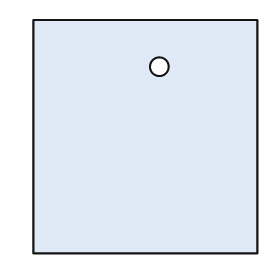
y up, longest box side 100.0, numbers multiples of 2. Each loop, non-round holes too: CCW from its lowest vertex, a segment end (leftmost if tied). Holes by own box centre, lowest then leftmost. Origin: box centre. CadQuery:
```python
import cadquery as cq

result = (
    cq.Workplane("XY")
    .moveTo(-48.0, -50.0)
    .lineTo(48.0, -50.0)
    .lineTo(48.0, 50.0)
    .lineTo(-48.0, 50.0)
    .close()
    .moveTo(6.0, 30.0)
    .circle(4.0)
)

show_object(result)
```